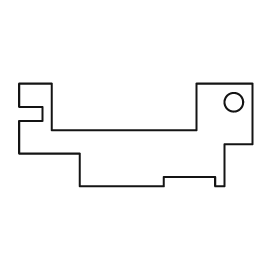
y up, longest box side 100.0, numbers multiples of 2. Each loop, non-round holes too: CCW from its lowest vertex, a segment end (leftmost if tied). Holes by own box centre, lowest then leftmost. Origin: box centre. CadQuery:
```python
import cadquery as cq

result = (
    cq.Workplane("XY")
    .moveTo(-24.0, -22.0)
    .lineTo(12.0, -22.0)
    .lineTo(12.0, -18.0)
    .lineTo(34.0, -18.0)
    .lineTo(34.0, -22.0)
    .lineTo(38.0, -22.0)
    .lineTo(38.0, -4.0)
    .lineTo(50.0, -4.0)
    .lineTo(50.0, 22.0)
    .lineTo(26.0, 22.0)
    .lineTo(26.0, 2.0)
    .lineTo(-36.0, 2.0)
    .lineTo(-36.0, 22.0)
    .lineTo(-50.0, 22.0)
    .lineTo(-50.0, 12.0)
    .lineTo(-40.0, 12.0)
    .lineTo(-40.0, 6.0)
    .lineTo(-50.0, 6.0)
    .lineTo(-50.0, -8.0)
    .lineTo(-24.0, -8.0)
    .close()
    .moveTo(42.0, 14.0)
    .circle(4.0)
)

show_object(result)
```